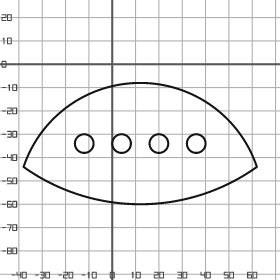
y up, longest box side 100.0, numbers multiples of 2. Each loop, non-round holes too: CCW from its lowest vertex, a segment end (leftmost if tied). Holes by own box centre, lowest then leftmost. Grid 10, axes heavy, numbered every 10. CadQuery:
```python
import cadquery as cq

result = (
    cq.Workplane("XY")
    .moveTo(-38.0, -44.0)
    .threePointArc((12.0, -60.0), (62.0, -44.0))
    .threePointArc((12.0, -8.0), (-38.0, -44.0))
    .close()
    .moveTo(-12.0, -34.0)
    .circle(4.0)
    .moveTo(4.0, -34.0)
    .circle(4.0)
    .moveTo(20.0, -34.0)
    .circle(4.0)
    .moveTo(36.0, -34.0)
    .circle(4.0)
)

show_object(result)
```